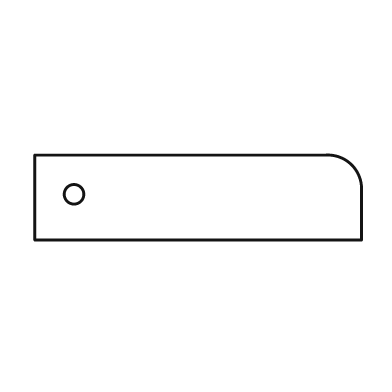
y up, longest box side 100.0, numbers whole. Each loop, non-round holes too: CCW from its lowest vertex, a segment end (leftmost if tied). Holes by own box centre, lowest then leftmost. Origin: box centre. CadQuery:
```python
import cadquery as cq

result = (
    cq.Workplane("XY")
    .moveTo(-50.0, -13.0)
    .lineTo(50.0, -13.0)
    .lineTo(50.0, 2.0)
    .threePointArc((47.0, 10.0), (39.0, 13.0))
    .lineTo(-50.0, 13.0)
    .close()
    .moveTo(-38.0, 1.0)
    .circle(3.0)
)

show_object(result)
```